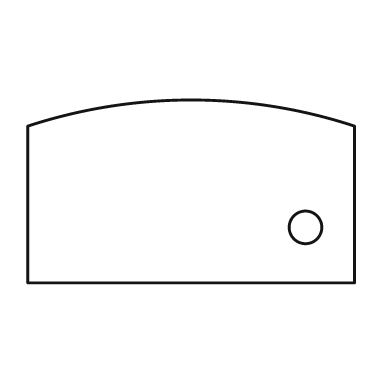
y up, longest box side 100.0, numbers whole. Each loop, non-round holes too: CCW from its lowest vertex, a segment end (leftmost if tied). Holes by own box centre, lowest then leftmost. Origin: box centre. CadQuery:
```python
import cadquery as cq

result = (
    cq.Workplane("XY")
    .moveTo(-50.0, -28.0)
    .lineTo(50.0, -28.0)
    .lineTo(50.0, 20.0)
    .threePointArc((0.0, 28.0), (-50.0, 20.0))
    .close()
    .moveTo(35.0, -11.0)
    .circle(5.0)
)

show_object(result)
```